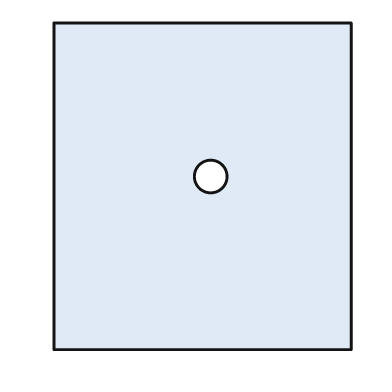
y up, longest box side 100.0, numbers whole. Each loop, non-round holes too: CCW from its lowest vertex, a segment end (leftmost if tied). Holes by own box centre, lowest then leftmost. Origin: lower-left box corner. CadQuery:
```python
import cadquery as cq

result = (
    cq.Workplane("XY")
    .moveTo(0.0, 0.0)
    .lineTo(91.0, 0.0)
    .lineTo(91.0, 100.0)
    .lineTo(0.0, 100.0)
    .close()
    .moveTo(48.0, 53.0)
    .circle(5.0)
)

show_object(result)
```